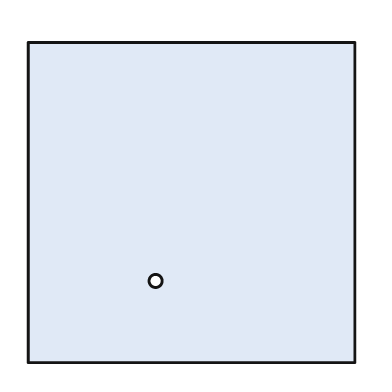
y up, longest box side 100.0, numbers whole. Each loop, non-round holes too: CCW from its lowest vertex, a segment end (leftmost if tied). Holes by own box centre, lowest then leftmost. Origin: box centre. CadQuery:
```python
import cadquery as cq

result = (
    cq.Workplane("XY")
    .moveTo(-50.0, -49.0)
    .lineTo(50.0, -49.0)
    .lineTo(50.0, 49.0)
    .lineTo(-50.0, 49.0)
    .close()
    .moveTo(-11.0, -24.0)
    .circle(2.0)
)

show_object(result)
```